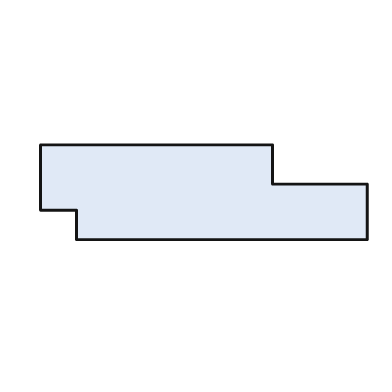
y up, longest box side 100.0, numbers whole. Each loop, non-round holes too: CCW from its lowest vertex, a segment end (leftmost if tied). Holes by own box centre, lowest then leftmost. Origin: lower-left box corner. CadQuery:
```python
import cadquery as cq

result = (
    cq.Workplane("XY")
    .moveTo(11.0, 0.0)
    .lineTo(100.0, 0.0)
    .lineTo(100.0, 17.0)
    .lineTo(71.0, 17.0)
    .lineTo(71.0, 29.0)
    .lineTo(0.0, 29.0)
    .lineTo(0.0, 9.0)
    .lineTo(11.0, 9.0)
    .close()
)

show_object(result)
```